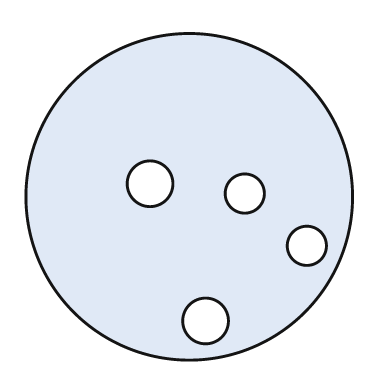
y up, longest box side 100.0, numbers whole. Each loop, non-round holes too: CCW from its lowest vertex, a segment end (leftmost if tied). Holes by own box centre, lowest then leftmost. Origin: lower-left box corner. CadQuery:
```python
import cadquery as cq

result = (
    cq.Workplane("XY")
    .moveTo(50.0, 50.0)
    .circle(50.0)
    .moveTo(55.0, 12.0)
    .circle(7.0)
    .moveTo(86.0, 35.0)
    .circle(6.0)
    .moveTo(67.0, 51.0)
    .circle(6.0)
    .moveTo(38.0, 54.0)
    .circle(7.0)
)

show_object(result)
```